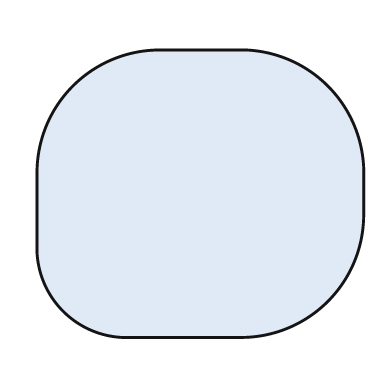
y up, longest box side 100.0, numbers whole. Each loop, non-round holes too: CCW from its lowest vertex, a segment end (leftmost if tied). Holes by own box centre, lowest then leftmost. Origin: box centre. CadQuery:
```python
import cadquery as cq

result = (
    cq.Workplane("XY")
    .moveTo(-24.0, -44.0)
    .lineTo(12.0, -44.0)
    .threePointArc((39.0, -33.0), (50.0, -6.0))
    .lineTo(50.0, 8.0)
    .threePointArc((39.0, 33.0), (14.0, 44.0))
    .lineTo(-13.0, 44.0)
    .threePointArc((-39.0, 33.0), (-50.0, 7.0))
    .lineTo(-50.0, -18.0)
    .threePointArc((-42.0, -36.0), (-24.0, -44.0))
    .close()
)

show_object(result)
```